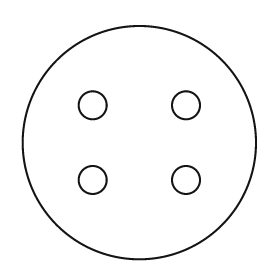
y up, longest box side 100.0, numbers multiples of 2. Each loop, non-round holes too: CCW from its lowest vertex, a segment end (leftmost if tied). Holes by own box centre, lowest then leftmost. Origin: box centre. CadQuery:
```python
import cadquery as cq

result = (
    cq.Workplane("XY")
    .moveTo(0.0, 0.0)
    .circle(50.0)
    .moveTo(-20.0, -16.0)
    .circle(6.0)
    .moveTo(20.0, -16.0)
    .circle(6.0)
    .moveTo(-20.0, 16.0)
    .circle(6.0)
    .moveTo(20.0, 16.0)
    .circle(6.0)
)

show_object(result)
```